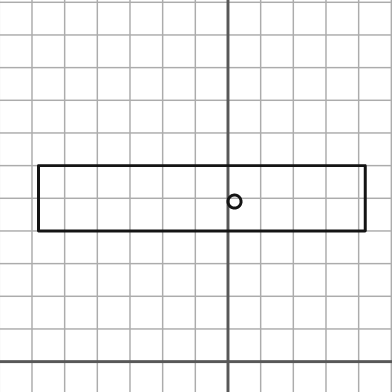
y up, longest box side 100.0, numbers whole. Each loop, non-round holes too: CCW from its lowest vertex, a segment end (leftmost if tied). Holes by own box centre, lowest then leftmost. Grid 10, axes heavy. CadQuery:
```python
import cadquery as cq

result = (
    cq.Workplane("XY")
    .moveTo(-58.0, 40.0)
    .lineTo(42.0, 40.0)
    .lineTo(42.0, 60.0)
    .lineTo(-58.0, 60.0)
    .close()
    .moveTo(2.0, 49.0)
    .circle(2.0)
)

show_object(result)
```